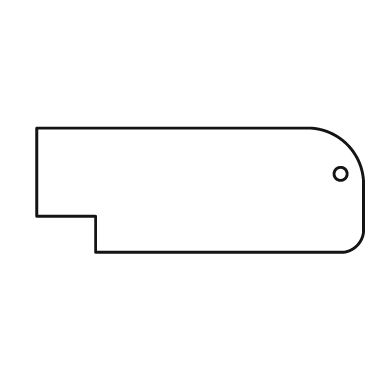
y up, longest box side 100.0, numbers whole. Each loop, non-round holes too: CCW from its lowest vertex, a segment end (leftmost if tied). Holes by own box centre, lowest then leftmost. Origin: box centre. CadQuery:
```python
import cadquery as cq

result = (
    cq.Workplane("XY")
    .moveTo(-32.0, -19.0)
    .lineTo(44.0, -19.0)
    .threePointArc((48.0, -17.0), (50.0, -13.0))
    .lineTo(50.0, 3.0)
    .threePointArc((45.0, 14.0), (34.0, 19.0))
    .lineTo(-50.0, 19.0)
    .lineTo(-50.0, -8.0)
    .lineTo(-32.0, -8.0)
    .close()
    .moveTo(43.0, 5.0)
    .circle(2.0)
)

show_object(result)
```